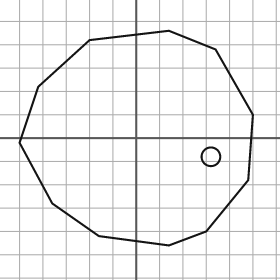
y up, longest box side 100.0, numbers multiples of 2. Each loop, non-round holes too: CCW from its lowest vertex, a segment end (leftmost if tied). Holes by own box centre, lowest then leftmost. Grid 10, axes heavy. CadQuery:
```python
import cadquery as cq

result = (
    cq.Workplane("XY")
    .moveTo(14.0, -46.0)
    .lineTo(30.0, -40.0)
    .lineTo(48.0, -18.0)
    .lineTo(50.0, 10.0)
    .lineTo(34.0, 38.0)
    .lineTo(14.0, 46.0)
    .lineTo(-20.0, 42.0)
    .lineTo(-42.0, 22.0)
    .lineTo(-50.0, -2.0)
    .lineTo(-36.0, -28.0)
    .lineTo(-16.0, -42.0)
    .close()
    .moveTo(32.0, -8.0)
    .circle(4.0)
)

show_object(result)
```